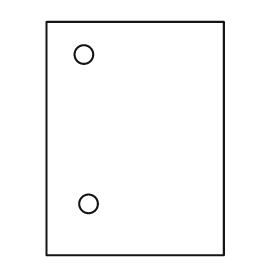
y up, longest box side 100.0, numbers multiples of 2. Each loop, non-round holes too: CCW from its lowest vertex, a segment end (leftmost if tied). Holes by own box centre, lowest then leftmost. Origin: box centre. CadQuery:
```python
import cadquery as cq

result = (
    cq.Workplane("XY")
    .moveTo(-38.0, -50.0)
    .lineTo(38.0, -50.0)
    .lineTo(38.0, 50.0)
    .lineTo(-38.0, 50.0)
    .close()
    .moveTo(-20.0, -28.0)
    .circle(4.0)
    .moveTo(-22.0, 36.0)
    .circle(4.0)
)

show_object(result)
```